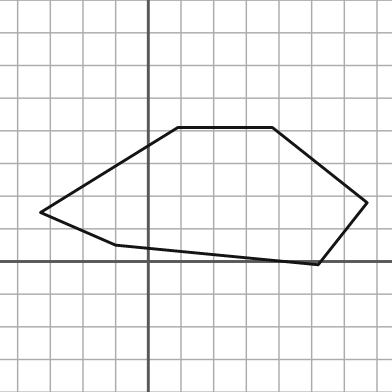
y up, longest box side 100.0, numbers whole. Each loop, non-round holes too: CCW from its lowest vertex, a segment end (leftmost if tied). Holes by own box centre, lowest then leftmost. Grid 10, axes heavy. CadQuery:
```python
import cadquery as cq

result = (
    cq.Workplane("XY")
    .moveTo(52.0, -1.0)
    .lineTo(67.0, 18.0)
    .lineTo(38.0, 41.0)
    .lineTo(9.0, 41.0)
    .lineTo(-33.0, 15.0)
    .lineTo(-10.0, 5.0)
    .close()
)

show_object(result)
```